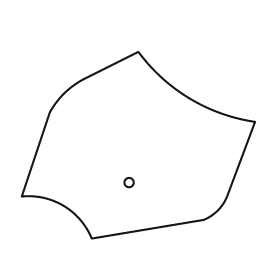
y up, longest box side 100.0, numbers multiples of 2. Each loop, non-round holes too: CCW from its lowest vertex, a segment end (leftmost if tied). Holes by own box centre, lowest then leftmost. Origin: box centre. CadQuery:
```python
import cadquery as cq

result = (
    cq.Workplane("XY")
    .moveTo(-20.0, -40.0)
    .lineTo(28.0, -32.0)
    .threePointArc((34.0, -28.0), (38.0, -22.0))
    .lineTo(50.0, 10.0)
    .threePointArc((22.0, 20.0), (0.0, 40.0))
    .lineTo(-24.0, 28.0)
    .threePointArc((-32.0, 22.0), (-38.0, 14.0))
    .lineTo(-50.0, -22.0)
    .threePointArc((-32.0, -26.0), (-20.0, -40.0))
    .close()
    .moveTo(-4.0, -16.0)
    .circle(2.0)
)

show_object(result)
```